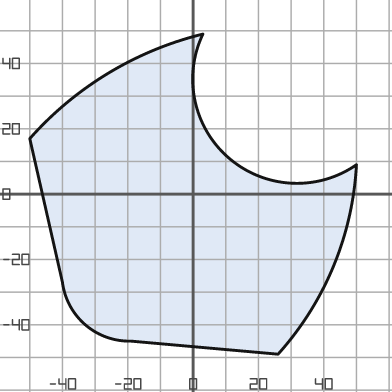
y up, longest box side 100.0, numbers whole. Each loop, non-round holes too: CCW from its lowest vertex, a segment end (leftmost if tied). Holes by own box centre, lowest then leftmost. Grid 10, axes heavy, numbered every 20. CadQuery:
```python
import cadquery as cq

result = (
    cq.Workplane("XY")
    .moveTo(26.0, -49.0)
    .threePointArc((43.0, -22.0), (50.0, 9.0))
    .threePointArc((11.0, 11.0), (3.0, 49.0))
    .threePointArc((-26.0, 37.0), (-50.0, 17.0))
    .lineTo(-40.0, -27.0)
    .threePointArc((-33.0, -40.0), (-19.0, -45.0))
    .close()
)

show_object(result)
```